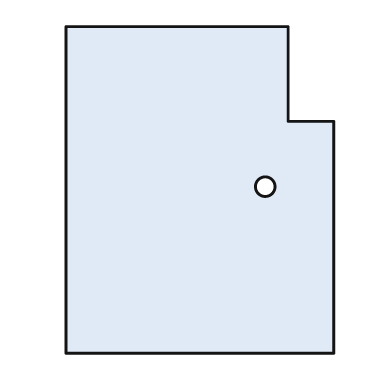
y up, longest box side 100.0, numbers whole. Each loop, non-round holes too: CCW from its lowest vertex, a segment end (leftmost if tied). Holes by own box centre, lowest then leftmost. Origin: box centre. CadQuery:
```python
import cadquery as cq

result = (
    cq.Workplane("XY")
    .moveTo(-41.0, -50.0)
    .lineTo(41.0, -50.0)
    .lineTo(41.0, 21.0)
    .lineTo(27.0, 21.0)
    .lineTo(27.0, 50.0)
    .lineTo(-41.0, 50.0)
    .close()
    .moveTo(20.0, 1.0)
    .circle(3.0)
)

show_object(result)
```